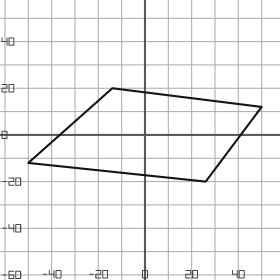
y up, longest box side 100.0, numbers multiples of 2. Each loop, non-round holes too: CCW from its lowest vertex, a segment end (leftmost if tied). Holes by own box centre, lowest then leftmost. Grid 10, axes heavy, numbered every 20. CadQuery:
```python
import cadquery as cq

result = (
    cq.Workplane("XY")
    .moveTo(26.0, -20.0)
    .lineTo(50.0, 12.0)
    .lineTo(-14.0, 20.0)
    .lineTo(-50.0, -12.0)
    .close()
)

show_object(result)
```